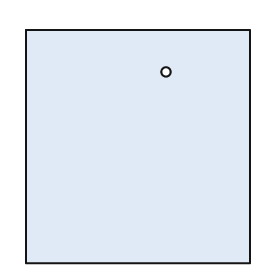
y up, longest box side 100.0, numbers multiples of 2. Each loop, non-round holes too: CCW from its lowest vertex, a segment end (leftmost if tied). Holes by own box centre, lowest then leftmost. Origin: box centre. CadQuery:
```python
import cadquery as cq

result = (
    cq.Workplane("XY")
    .moveTo(-48.0, -50.0)
    .lineTo(48.0, -50.0)
    .lineTo(48.0, 50.0)
    .lineTo(-48.0, 50.0)
    .close()
    .moveTo(12.0, 32.0)
    .circle(2.0)
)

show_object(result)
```